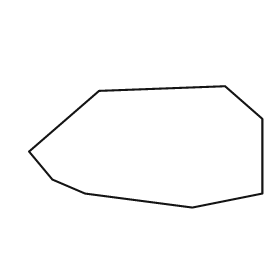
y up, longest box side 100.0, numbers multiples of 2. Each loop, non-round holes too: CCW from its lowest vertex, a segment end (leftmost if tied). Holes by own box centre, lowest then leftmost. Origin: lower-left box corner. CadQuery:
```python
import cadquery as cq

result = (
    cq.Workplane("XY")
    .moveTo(70.0, 0.0)
    .lineTo(100.0, 6.0)
    .lineTo(100.0, 38.0)
    .lineTo(84.0, 52.0)
    .lineTo(30.0, 50.0)
    .lineTo(0.0, 24.0)
    .lineTo(10.0, 12.0)
    .lineTo(24.0, 6.0)
    .close()
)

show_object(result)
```